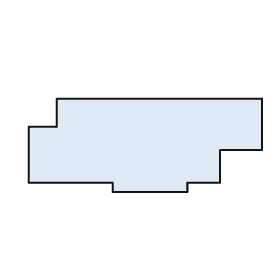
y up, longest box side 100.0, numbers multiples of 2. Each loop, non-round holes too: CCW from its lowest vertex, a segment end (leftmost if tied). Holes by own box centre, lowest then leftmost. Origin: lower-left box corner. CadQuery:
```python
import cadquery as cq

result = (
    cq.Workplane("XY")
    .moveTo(36.0, 0.0)
    .lineTo(68.0, 0.0)
    .lineTo(68.0, 4.0)
    .lineTo(82.0, 4.0)
    .lineTo(82.0, 18.0)
    .lineTo(100.0, 18.0)
    .lineTo(100.0, 40.0)
    .lineTo(12.0, 40.0)
    .lineTo(12.0, 28.0)
    .lineTo(0.0, 28.0)
    .lineTo(0.0, 4.0)
    .lineTo(36.0, 4.0)
    .close()
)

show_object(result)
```